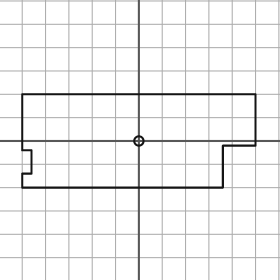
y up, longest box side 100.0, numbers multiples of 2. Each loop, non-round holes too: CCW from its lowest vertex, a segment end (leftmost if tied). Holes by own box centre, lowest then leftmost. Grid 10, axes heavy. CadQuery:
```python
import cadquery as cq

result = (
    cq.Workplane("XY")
    .moveTo(-50.0, -20.0)
    .lineTo(36.0, -20.0)
    .lineTo(36.0, -2.0)
    .lineTo(50.0, -2.0)
    .lineTo(50.0, 20.0)
    .lineTo(-50.0, 20.0)
    .lineTo(-50.0, -4.0)
    .lineTo(-46.0, -4.0)
    .lineTo(-46.0, -14.0)
    .lineTo(-50.0, -14.0)
    .close()
    .moveTo(0.0, 0.0)
    .circle(2.0)
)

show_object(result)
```